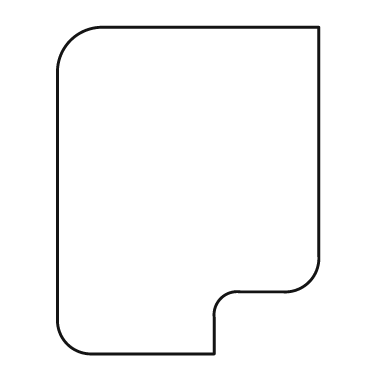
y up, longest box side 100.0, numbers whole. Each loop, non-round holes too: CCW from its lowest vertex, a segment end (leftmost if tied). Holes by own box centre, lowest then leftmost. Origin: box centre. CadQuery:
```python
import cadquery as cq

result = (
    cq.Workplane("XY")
    .moveTo(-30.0, -50.0)
    .lineTo(8.0, -50.0)
    .lineTo(8.0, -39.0)
    .threePointArc((10.0, -33.0), (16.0, -31.0))
    .lineTo(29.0, -31.0)
    .threePointArc((37.0, -28.0), (40.0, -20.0))
    .lineTo(40.0, 50.0)
    .lineTo(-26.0, 50.0)
    .threePointArc((-36.0, 46.0), (-40.0, 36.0))
    .lineTo(-40.0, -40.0)
    .threePointArc((-37.0, -47.0), (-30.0, -50.0))
    .close()
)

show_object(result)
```